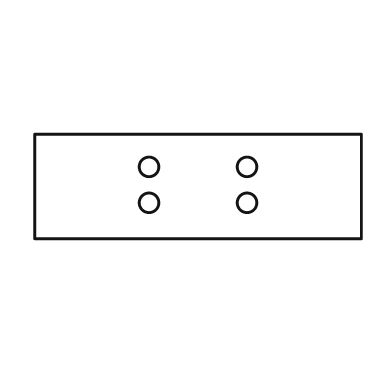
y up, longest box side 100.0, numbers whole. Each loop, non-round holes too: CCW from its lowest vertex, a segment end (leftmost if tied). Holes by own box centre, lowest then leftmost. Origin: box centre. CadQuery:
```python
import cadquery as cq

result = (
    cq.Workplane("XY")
    .moveTo(-50.0, -16.0)
    .lineTo(50.0, -16.0)
    .lineTo(50.0, 16.0)
    .lineTo(-50.0, 16.0)
    .close()
    .moveTo(-15.0, -5.0)
    .circle(3.0)
    .moveTo(15.0, -5.0)
    .circle(3.0)
    .moveTo(-15.0, 6.0)
    .circle(3.0)
    .moveTo(15.0, 6.0)
    .circle(3.0)
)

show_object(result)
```